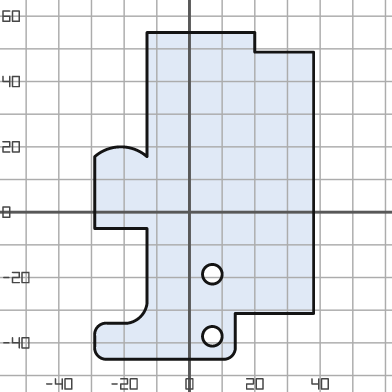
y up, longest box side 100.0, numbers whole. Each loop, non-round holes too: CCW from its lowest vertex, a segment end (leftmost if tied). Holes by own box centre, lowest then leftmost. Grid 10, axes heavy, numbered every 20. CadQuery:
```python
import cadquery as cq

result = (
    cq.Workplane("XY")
    .moveTo(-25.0, -45.0)
    .lineTo(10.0, -45.0)
    .threePointArc((13.0, -44.0), (14.0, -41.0))
    .lineTo(14.0, -31.0)
    .lineTo(38.0, -31.0)
    .lineTo(38.0, 49.0)
    .lineTo(20.0, 49.0)
    .lineTo(20.0, 55.0)
    .lineTo(-13.0, 55.0)
    .lineTo(-13.0, 17.0)
    .threePointArc((-21.0, 20.0), (-29.0, 17.0))
    .lineTo(-29.0, -5.0)
    .lineTo(-13.0, -5.0)
    .lineTo(-13.0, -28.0)
    .threePointArc((-15.0, -32.0), (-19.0, -34.0))
    .lineTo(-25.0, -34.0)
    .threePointArc((-28.0, -35.0), (-29.0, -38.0))
    .lineTo(-29.0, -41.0)
    .threePointArc((-28.0, -44.0), (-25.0, -45.0))
    .close()
    .moveTo(7.0, -38.0)
    .circle(3.0)
    .moveTo(7.0, -19.0)
    .circle(3.0)
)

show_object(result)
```